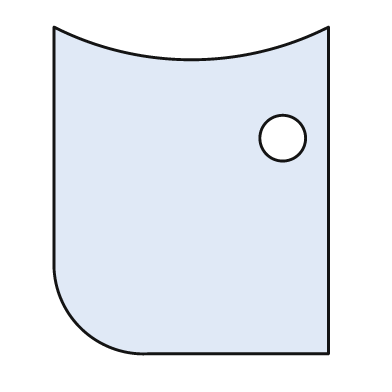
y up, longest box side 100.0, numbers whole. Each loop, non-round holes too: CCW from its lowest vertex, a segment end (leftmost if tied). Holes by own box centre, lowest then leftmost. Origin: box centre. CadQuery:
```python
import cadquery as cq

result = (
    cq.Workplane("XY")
    .moveTo(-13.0, -50.0)
    .lineTo(42.0, -50.0)
    .lineTo(42.0, 50.0)
    .threePointArc((0.0, 40.0), (-42.0, 50.0))
    .lineTo(-42.0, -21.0)
    .threePointArc((-34.0, -42.0), (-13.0, -50.0))
    .close()
    .moveTo(28.0, 16.0)
    .circle(7.0)
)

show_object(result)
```